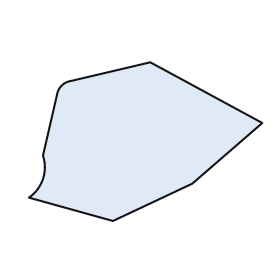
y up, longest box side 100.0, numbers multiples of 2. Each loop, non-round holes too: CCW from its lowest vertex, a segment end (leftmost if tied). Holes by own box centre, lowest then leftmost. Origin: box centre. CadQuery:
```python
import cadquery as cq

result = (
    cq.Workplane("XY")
    .moveTo(-14.0, -34.0)
    .lineTo(20.0, -18.0)
    .lineTo(50.0, 8.0)
    .lineTo(2.0, 34.0)
    .lineTo(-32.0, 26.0)
    .threePointArc((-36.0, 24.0), (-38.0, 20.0))
    .lineTo(-44.0, -6.0)
    .threePointArc((-44.0, -16.0), (-50.0, -24.0))
    .close()
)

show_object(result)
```